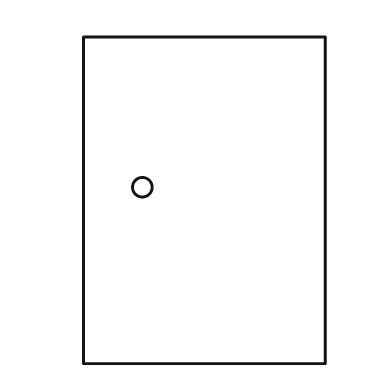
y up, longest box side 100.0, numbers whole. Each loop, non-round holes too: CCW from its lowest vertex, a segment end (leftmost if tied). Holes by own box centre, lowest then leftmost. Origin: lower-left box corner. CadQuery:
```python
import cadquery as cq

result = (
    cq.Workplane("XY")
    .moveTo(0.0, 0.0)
    .lineTo(74.0, 0.0)
    .lineTo(74.0, 100.0)
    .lineTo(0.0, 100.0)
    .close()
    .moveTo(18.0, 54.0)
    .circle(3.0)
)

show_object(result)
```